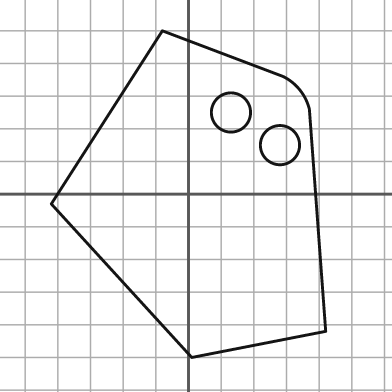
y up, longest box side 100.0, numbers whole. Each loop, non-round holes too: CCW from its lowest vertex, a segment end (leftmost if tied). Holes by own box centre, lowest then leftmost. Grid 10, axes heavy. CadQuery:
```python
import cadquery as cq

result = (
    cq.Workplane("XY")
    .moveTo(1.0, -50.0)
    .lineTo(42.0, -42.0)
    .lineTo(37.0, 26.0)
    .threePointArc((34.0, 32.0), (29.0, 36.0))
    .lineTo(-8.0, 50.0)
    .lineTo(-42.0, -3.0)
    .close()
    .moveTo(28.0, 15.0)
    .circle(6.0)
    .moveTo(13.0, 25.0)
    .circle(6.0)
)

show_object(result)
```